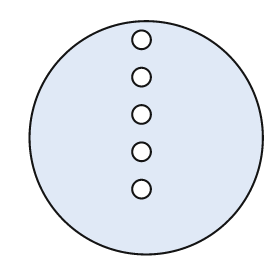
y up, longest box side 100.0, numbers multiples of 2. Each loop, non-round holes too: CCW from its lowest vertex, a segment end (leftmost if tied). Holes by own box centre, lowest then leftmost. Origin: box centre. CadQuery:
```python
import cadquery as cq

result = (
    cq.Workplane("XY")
    .moveTo(0.0, 0.0)
    .circle(50.0)
    .moveTo(-2.0, -22.0)
    .circle(4.0)
    .moveTo(-2.0, -6.0)
    .circle(4.0)
    .moveTo(-2.0, 10.0)
    .circle(4.0)
    .moveTo(-2.0, 26.0)
    .circle(4.0)
    .moveTo(-2.0, 42.0)
    .circle(4.0)
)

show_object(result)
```